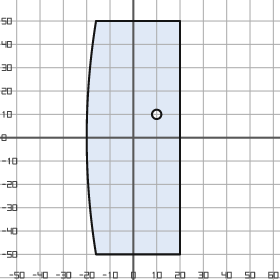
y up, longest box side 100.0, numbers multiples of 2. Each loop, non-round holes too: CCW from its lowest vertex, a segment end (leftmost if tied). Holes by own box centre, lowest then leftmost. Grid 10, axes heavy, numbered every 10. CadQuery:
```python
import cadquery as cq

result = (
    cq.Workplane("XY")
    .moveTo(-16.0, -50.0)
    .lineTo(20.0, -50.0)
    .lineTo(20.0, 50.0)
    .lineTo(-16.0, 50.0)
    .threePointArc((-20.0, 0.0), (-16.0, -50.0))
    .close()
    .moveTo(10.0, 10.0)
    .circle(2.0)
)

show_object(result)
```